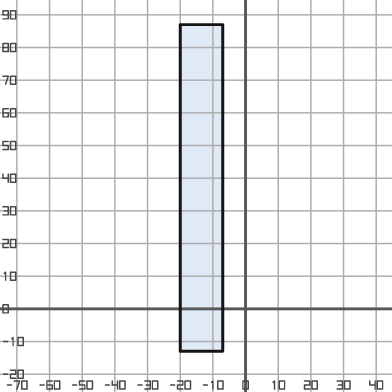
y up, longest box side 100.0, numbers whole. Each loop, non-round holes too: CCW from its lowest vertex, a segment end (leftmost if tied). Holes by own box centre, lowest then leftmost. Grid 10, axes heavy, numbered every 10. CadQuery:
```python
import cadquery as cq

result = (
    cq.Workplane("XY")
    .moveTo(-20.0, -13.0)
    .lineTo(-7.0, -13.0)
    .lineTo(-7.0, 87.0)
    .lineTo(-20.0, 87.0)
    .close()
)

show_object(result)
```